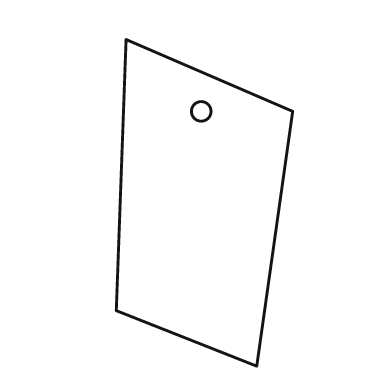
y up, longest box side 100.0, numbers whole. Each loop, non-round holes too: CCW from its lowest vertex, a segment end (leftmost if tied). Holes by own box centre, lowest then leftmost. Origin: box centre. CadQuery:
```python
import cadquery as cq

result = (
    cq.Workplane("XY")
    .moveTo(16.0, -50.0)
    .lineTo(27.0, 28.0)
    .lineTo(-24.0, 50.0)
    .lineTo(-27.0, -33.0)
    .close()
    .moveTo(-1.0, 28.0)
    .circle(3.0)
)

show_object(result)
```